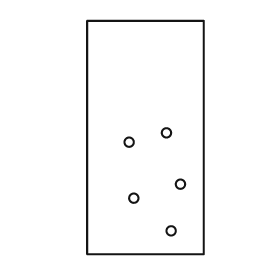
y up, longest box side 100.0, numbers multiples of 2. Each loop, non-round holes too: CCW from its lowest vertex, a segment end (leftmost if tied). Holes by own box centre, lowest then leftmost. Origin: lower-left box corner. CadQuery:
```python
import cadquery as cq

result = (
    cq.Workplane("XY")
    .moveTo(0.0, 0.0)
    .lineTo(50.0, 0.0)
    .lineTo(50.0, 100.0)
    .lineTo(0.0, 100.0)
    .close()
    .moveTo(36.0, 10.0)
    .circle(2.0)
    .moveTo(20.0, 24.0)
    .circle(2.0)
    .moveTo(40.0, 30.0)
    .circle(2.0)
    .moveTo(18.0, 48.0)
    .circle(2.0)
    .moveTo(34.0, 52.0)
    .circle(2.0)
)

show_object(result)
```